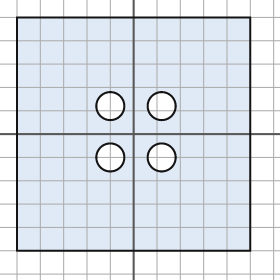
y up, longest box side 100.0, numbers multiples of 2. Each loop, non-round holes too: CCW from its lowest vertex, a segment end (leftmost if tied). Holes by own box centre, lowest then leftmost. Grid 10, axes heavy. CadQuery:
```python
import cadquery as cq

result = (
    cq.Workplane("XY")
    .moveTo(-50.0, -50.0)
    .lineTo(50.0, -50.0)
    .lineTo(50.0, 50.0)
    .lineTo(-50.0, 50.0)
    .close()
    .moveTo(-10.0, -10.0)
    .circle(6.0)
    .moveTo(12.0, -10.0)
    .circle(6.0)
    .moveTo(-10.0, 12.0)
    .circle(6.0)
    .moveTo(12.0, 12.0)
    .circle(6.0)
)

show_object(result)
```